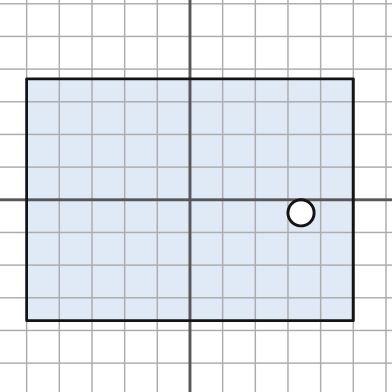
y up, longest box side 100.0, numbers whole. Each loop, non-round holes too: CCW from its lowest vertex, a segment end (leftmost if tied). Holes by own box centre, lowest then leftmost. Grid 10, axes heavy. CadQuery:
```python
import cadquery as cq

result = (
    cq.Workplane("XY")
    .moveTo(-50.0, -37.0)
    .lineTo(50.0, -37.0)
    .lineTo(50.0, 37.0)
    .lineTo(-50.0, 37.0)
    .close()
    .moveTo(34.0, -4.0)
    .circle(4.0)
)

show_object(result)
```